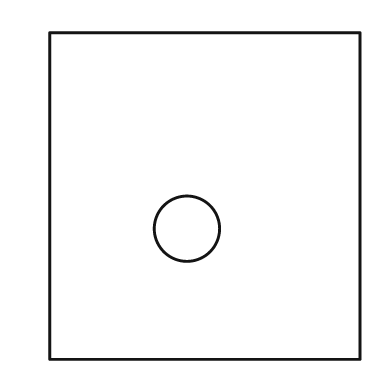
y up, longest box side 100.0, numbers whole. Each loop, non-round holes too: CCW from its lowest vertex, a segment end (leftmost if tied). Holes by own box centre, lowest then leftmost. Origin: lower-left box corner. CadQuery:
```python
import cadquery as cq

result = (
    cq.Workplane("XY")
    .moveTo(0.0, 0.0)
    .lineTo(95.0, 0.0)
    .lineTo(95.0, 100.0)
    .lineTo(0.0, 100.0)
    .close()
    .moveTo(42.0, 40.0)
    .circle(10.0)
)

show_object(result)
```